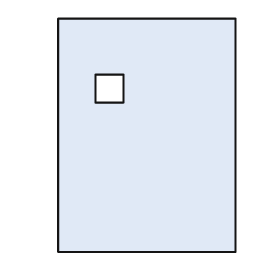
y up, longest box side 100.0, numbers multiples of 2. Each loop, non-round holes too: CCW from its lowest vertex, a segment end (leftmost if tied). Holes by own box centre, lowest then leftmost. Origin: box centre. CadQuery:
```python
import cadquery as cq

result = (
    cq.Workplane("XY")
    .moveTo(-38.0, -50.0)
    .lineTo(38.0, -50.0)
    .lineTo(38.0, 50.0)
    .lineTo(-38.0, 50.0)
    .close()
    .moveTo(-22.0, 14.0)
    .lineTo(-10.0, 14.0)
    .lineTo(-10.0, 26.0)
    .lineTo(-22.0, 26.0)
    .close()
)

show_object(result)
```